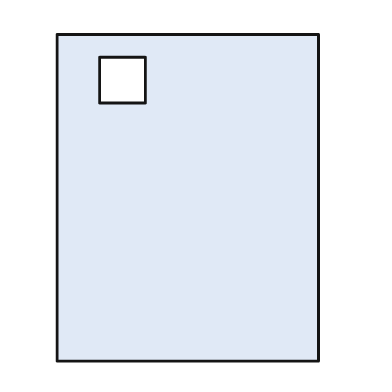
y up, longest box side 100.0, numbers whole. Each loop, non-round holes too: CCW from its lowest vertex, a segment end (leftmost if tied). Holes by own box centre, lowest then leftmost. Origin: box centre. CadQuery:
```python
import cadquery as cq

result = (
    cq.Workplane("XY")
    .moveTo(-40.0, -50.0)
    .lineTo(40.0, -50.0)
    .lineTo(40.0, 50.0)
    .lineTo(-40.0, 50.0)
    .close()
    .moveTo(-27.0, 29.0)
    .lineTo(-13.0, 29.0)
    .lineTo(-13.0, 43.0)
    .lineTo(-27.0, 43.0)
    .close()
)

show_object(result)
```